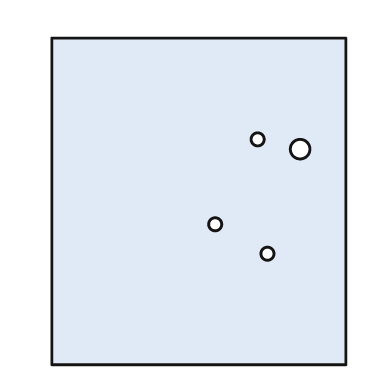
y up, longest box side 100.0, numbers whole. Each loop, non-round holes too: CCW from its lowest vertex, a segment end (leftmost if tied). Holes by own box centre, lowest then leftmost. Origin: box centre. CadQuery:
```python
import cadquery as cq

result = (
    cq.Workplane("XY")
    .moveTo(-45.0, -50.0)
    .lineTo(45.0, -50.0)
    .lineTo(45.0, 50.0)
    .lineTo(-45.0, 50.0)
    .close()
    .moveTo(21.0, -16.0)
    .circle(2.0)
    .moveTo(5.0, -7.0)
    .circle(2.0)
    .moveTo(31.0, 16.0)
    .circle(3.0)
    .moveTo(18.0, 19.0)
    .circle(2.0)
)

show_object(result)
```